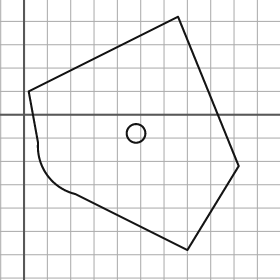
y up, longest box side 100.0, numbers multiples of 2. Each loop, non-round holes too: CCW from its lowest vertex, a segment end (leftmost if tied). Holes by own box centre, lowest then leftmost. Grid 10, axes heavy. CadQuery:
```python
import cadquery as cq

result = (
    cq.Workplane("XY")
    .moveTo(70.0, -58.0)
    .lineTo(92.0, -22.0)
    .lineTo(66.0, 42.0)
    .lineTo(2.0, 10.0)
    .lineTo(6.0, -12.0)
    .threePointArc((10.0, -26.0), (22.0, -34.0))
    .close()
    .moveTo(48.0, -8.0)
    .circle(4.0)
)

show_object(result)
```